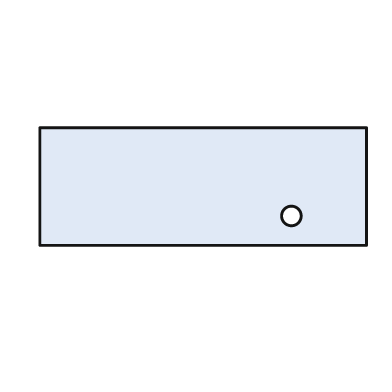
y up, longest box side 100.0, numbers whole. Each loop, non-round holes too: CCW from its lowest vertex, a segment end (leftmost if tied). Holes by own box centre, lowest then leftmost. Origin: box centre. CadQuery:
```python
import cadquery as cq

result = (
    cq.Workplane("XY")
    .moveTo(-50.0, -18.0)
    .lineTo(50.0, -18.0)
    .lineTo(50.0, 18.0)
    .lineTo(-50.0, 18.0)
    .close()
    .moveTo(27.0, -9.0)
    .circle(3.0)
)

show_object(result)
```